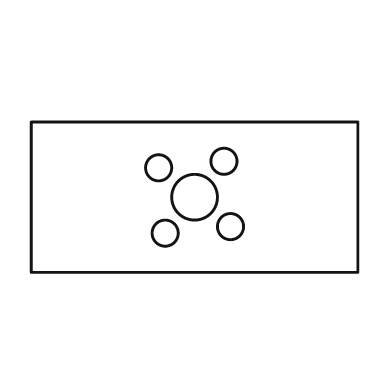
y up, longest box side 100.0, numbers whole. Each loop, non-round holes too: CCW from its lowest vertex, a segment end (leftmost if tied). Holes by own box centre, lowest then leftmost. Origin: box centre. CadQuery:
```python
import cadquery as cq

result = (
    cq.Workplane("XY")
    .moveTo(-50.0, -23.0)
    .lineTo(50.0, -23.0)
    .lineTo(50.0, 23.0)
    .lineTo(-50.0, 23.0)
    .close()
    .moveTo(-9.0, -11.0)
    .circle(4.0)
    .moveTo(11.0, -9.0)
    .circle(4.0)
    .moveTo(0.0, 0.0)
    .circle(7.0)
    .moveTo(-11.0, 9.0)
    .circle(4.0)
    .moveTo(9.0, 11.0)
    .circle(4.0)
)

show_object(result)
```